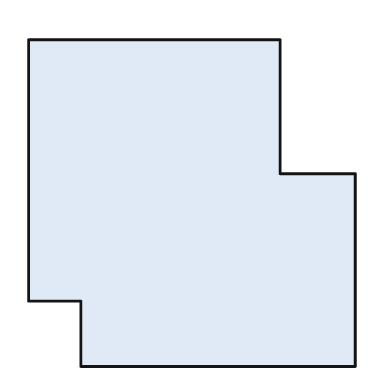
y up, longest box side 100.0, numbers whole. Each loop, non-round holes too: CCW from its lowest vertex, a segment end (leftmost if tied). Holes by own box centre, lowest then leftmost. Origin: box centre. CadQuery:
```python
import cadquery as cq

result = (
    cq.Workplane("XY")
    .moveTo(-34.0, -50.0)
    .lineTo(50.0, -50.0)
    .lineTo(50.0, 9.0)
    .lineTo(27.0, 9.0)
    .lineTo(27.0, 50.0)
    .lineTo(-50.0, 50.0)
    .lineTo(-50.0, -30.0)
    .lineTo(-34.0, -30.0)
    .close()
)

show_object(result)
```